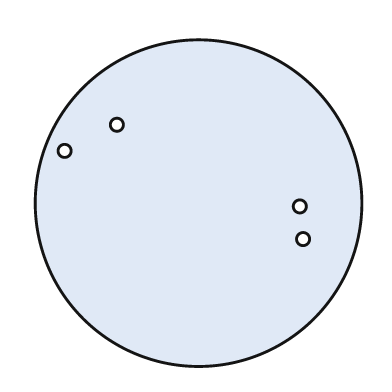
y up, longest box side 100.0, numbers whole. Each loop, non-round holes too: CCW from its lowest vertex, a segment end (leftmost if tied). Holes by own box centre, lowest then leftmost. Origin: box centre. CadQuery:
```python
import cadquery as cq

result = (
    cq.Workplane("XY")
    .moveTo(0.0, 0.0)
    .circle(50.0)
    .moveTo(32.0, -11.0)
    .circle(2.0)
    .moveTo(31.0, -1.0)
    .circle(2.0)
    .moveTo(-41.0, 16.0)
    .circle(2.0)
    .moveTo(-25.0, 24.0)
    .circle(2.0)
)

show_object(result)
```